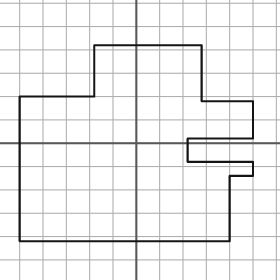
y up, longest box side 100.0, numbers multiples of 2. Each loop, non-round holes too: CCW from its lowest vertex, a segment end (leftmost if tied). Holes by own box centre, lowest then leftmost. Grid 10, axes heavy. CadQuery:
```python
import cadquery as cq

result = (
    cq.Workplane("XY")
    .moveTo(-50.0, -42.0)
    .lineTo(40.0, -42.0)
    .lineTo(40.0, -14.0)
    .lineTo(50.0, -14.0)
    .lineTo(50.0, -8.0)
    .lineTo(22.0, -8.0)
    .lineTo(22.0, 2.0)
    .lineTo(50.0, 2.0)
    .lineTo(50.0, 18.0)
    .lineTo(28.0, 18.0)
    .lineTo(28.0, 42.0)
    .lineTo(-18.0, 42.0)
    .lineTo(-18.0, 20.0)
    .lineTo(-50.0, 20.0)
    .close()
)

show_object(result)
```